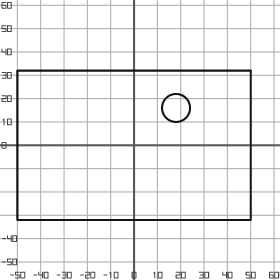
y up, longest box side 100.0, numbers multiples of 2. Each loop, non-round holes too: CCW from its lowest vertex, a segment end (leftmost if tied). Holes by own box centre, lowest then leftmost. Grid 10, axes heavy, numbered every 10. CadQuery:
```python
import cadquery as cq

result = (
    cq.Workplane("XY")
    .moveTo(-50.0, -32.0)
    .lineTo(50.0, -32.0)
    .lineTo(50.0, 32.0)
    .lineTo(-50.0, 32.0)
    .close()
    .moveTo(18.0, 16.0)
    .circle(6.0)
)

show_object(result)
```